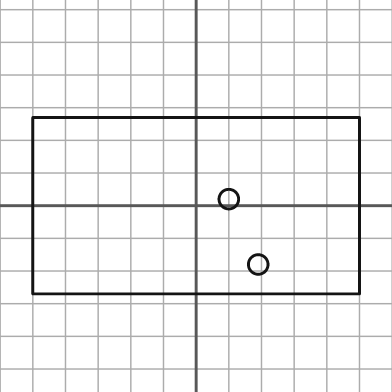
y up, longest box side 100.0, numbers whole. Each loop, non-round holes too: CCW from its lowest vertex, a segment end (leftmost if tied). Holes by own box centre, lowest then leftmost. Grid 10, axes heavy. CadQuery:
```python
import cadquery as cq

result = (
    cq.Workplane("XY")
    .moveTo(-50.0, -27.0)
    .lineTo(50.0, -27.0)
    .lineTo(50.0, 27.0)
    .lineTo(-50.0, 27.0)
    .close()
    .moveTo(19.0, -18.0)
    .circle(3.0)
    .moveTo(10.0, 2.0)
    .circle(3.0)
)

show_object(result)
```